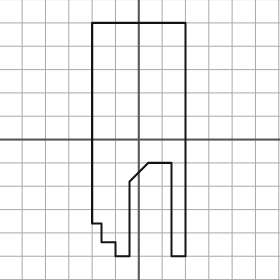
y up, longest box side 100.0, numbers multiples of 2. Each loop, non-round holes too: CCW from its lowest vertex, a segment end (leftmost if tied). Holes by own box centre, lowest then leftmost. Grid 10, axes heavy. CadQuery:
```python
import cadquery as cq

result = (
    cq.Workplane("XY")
    .moveTo(-10.0, -50.0)
    .lineTo(-4.0, -50.0)
    .lineTo(-4.0, -18.0)
    .lineTo(4.0, -10.0)
    .lineTo(14.0, -10.0)
    .lineTo(14.0, -50.0)
    .lineTo(20.0, -50.0)
    .lineTo(20.0, 50.0)
    .lineTo(-20.0, 50.0)
    .lineTo(-20.0, -36.0)
    .lineTo(-16.0, -36.0)
    .lineTo(-16.0, -44.0)
    .lineTo(-10.0, -44.0)
    .close()
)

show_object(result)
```